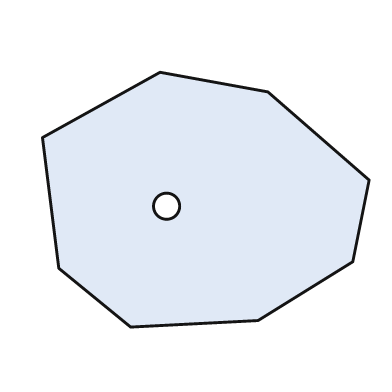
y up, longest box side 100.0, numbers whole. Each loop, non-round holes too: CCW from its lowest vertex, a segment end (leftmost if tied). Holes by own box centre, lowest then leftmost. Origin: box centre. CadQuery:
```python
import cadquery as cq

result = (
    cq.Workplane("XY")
    .moveTo(-23.0, -39.0)
    .lineTo(16.0, -37.0)
    .lineTo(45.0, -19.0)
    .lineTo(50.0, 6.0)
    .lineTo(19.0, 33.0)
    .lineTo(-14.0, 39.0)
    .lineTo(-50.0, 19.0)
    .lineTo(-45.0, -21.0)
    .close()
    .moveTo(-12.0, -2.0)
    .circle(4.0)
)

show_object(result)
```